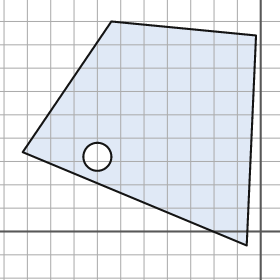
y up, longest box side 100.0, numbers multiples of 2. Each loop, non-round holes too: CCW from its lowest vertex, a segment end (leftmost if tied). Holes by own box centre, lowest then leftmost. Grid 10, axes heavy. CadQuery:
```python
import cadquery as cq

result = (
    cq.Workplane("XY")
    .moveTo(-6.0, -6.0)
    .lineTo(-2.0, 84.0)
    .lineTo(-64.0, 90.0)
    .lineTo(-102.0, 34.0)
    .close()
    .moveTo(-70.0, 32.0)
    .circle(6.0)
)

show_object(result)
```